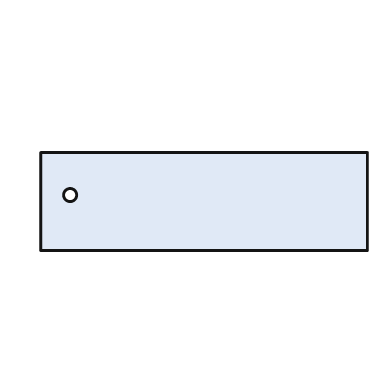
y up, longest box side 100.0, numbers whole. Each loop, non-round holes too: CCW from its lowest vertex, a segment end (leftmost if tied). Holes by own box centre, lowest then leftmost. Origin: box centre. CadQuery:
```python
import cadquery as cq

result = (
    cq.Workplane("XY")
    .moveTo(-50.0, -15.0)
    .lineTo(50.0, -15.0)
    .lineTo(50.0, 15.0)
    .lineTo(-50.0, 15.0)
    .close()
    .moveTo(-41.0, 2.0)
    .circle(2.0)
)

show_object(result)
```